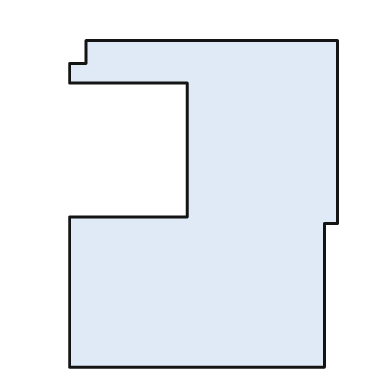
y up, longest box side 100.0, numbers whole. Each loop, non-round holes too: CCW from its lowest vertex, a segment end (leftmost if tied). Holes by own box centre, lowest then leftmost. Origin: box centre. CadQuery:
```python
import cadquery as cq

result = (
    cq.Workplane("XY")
    .moveTo(-41.0, -50.0)
    .lineTo(37.0, -50.0)
    .lineTo(37.0, -6.0)
    .lineTo(41.0, -6.0)
    .lineTo(41.0, 50.0)
    .lineTo(-36.0, 50.0)
    .lineTo(-36.0, 43.0)
    .lineTo(-41.0, 43.0)
    .lineTo(-41.0, 37.0)
    .lineTo(-5.0, 37.0)
    .lineTo(-5.0, -4.0)
    .lineTo(-41.0, -4.0)
    .close()
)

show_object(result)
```